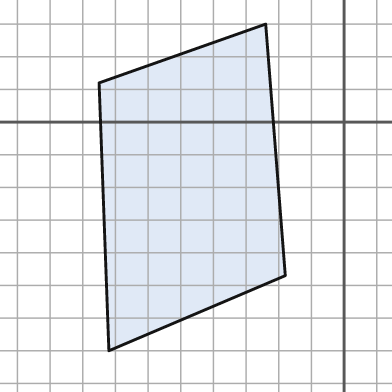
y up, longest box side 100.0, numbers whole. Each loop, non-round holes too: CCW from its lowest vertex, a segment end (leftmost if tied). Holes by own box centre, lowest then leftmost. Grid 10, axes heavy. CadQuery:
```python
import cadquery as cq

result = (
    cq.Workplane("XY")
    .moveTo(-72.0, -70.0)
    .lineTo(-18.0, -47.0)
    .lineTo(-24.0, 30.0)
    .lineTo(-75.0, 12.0)
    .close()
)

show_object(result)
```